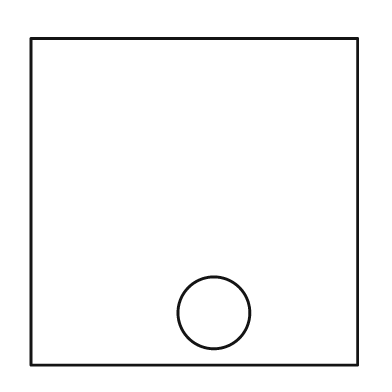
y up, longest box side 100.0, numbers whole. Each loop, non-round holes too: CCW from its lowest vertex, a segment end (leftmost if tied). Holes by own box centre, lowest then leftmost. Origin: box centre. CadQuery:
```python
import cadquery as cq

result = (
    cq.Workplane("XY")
    .moveTo(-50.0, -50.0)
    .lineTo(50.0, -50.0)
    .lineTo(50.0, 50.0)
    .lineTo(-50.0, 50.0)
    .close()
    .moveTo(6.0, -34.0)
    .circle(11.0)
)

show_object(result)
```